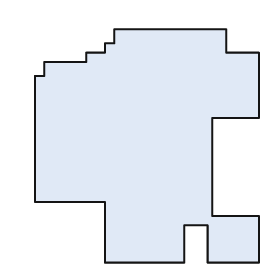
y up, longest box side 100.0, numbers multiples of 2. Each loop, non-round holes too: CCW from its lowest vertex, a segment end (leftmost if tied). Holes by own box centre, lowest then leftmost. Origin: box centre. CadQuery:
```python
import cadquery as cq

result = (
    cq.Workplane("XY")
    .moveTo(-18.0, -50.0)
    .lineTo(16.0, -50.0)
    .lineTo(16.0, -34.0)
    .lineTo(26.0, -34.0)
    .lineTo(26.0, -50.0)
    .lineTo(48.0, -50.0)
    .lineTo(48.0, -30.0)
    .lineTo(28.0, -30.0)
    .lineTo(28.0, 12.0)
    .lineTo(48.0, 12.0)
    .lineTo(48.0, 40.0)
    .lineTo(34.0, 40.0)
    .lineTo(34.0, 50.0)
    .lineTo(-14.0, 50.0)
    .lineTo(-14.0, 44.0)
    .lineTo(-18.0, 44.0)
    .lineTo(-18.0, 40.0)
    .lineTo(-26.0, 40.0)
    .lineTo(-26.0, 36.0)
    .lineTo(-44.0, 36.0)
    .lineTo(-44.0, 30.0)
    .lineTo(-48.0, 30.0)
    .lineTo(-48.0, -24.0)
    .lineTo(-18.0, -24.0)
    .close()
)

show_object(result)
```